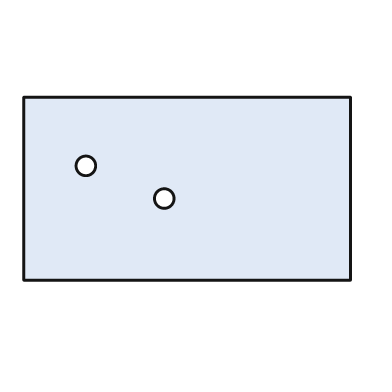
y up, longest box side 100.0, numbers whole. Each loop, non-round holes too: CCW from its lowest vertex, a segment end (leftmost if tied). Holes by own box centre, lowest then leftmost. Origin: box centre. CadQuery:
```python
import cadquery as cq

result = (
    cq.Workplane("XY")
    .moveTo(-50.0, -28.0)
    .lineTo(50.0, -28.0)
    .lineTo(50.0, 28.0)
    .lineTo(-50.0, 28.0)
    .close()
    .moveTo(-7.0, -3.0)
    .circle(3.0)
    .moveTo(-31.0, 7.0)
    .circle(3.0)
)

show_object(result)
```